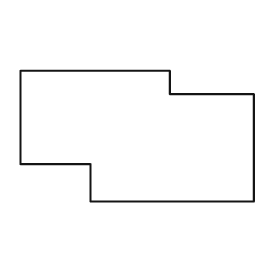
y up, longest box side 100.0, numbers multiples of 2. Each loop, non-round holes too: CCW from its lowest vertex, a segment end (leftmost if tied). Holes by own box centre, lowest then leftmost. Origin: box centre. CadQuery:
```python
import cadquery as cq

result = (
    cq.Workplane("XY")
    .moveTo(-20.0, -28.0)
    .lineTo(50.0, -28.0)
    .lineTo(50.0, 18.0)
    .lineTo(14.0, 18.0)
    .lineTo(14.0, 28.0)
    .lineTo(-50.0, 28.0)
    .lineTo(-50.0, -12.0)
    .lineTo(-20.0, -12.0)
    .close()
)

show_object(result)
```